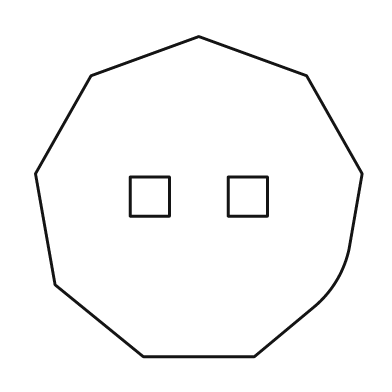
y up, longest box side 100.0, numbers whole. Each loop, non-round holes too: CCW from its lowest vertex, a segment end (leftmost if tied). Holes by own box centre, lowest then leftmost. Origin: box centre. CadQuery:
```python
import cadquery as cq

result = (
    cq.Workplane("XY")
    .moveTo(-17.0, -49.0)
    .lineTo(17.0, -49.0)
    .lineTo(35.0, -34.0)
    .threePointArc((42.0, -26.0), (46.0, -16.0))
    .lineTo(50.0, 7.0)
    .lineTo(33.0, 37.0)
    .lineTo(0.0, 49.0)
    .lineTo(-33.0, 37.0)
    .lineTo(-50.0, 7.0)
    .lineTo(-44.0, -27.0)
    .close()
    .moveTo(-21.0, -6.0)
    .lineTo(-9.0, -6.0)
    .lineTo(-9.0, 6.0)
    .lineTo(-21.0, 6.0)
    .close()
    .moveTo(9.0, -6.0)
    .lineTo(21.0, -6.0)
    .lineTo(21.0, 6.0)
    .lineTo(9.0, 6.0)
    .close()
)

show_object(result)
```